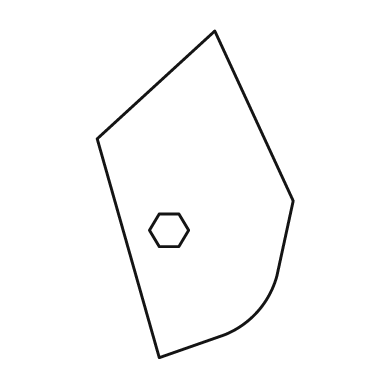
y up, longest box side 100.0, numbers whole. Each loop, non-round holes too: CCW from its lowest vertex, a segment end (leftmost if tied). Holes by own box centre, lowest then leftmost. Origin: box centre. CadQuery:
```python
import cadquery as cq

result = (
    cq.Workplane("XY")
    .moveTo(-11.0, -50.0)
    .lineTo(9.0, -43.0)
    .threePointArc((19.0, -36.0), (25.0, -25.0))
    .lineTo(30.0, -2.0)
    .lineTo(6.0, 50.0)
    .lineTo(-30.0, 17.0)
    .close()
    .moveTo(-11.0, -16.0)
    .lineTo(-5.0, -16.0)
    .lineTo(-2.0, -11.0)
    .lineTo(-5.0, -6.0)
    .lineTo(-11.0, -6.0)
    .lineTo(-14.0, -11.0)
    .close()
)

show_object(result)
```